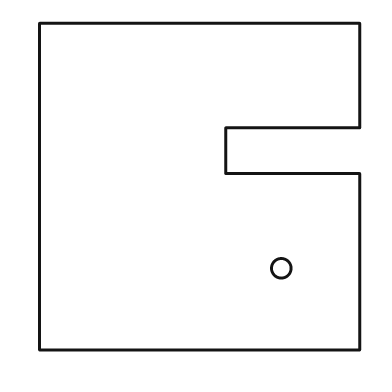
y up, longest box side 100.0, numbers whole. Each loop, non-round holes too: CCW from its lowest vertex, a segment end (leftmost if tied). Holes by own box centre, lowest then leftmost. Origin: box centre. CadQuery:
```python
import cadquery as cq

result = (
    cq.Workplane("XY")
    .moveTo(-49.0, -50.0)
    .lineTo(49.0, -50.0)
    .lineTo(49.0, 4.0)
    .lineTo(8.0, 4.0)
    .lineTo(8.0, 18.0)
    .lineTo(49.0, 18.0)
    .lineTo(49.0, 50.0)
    .lineTo(-49.0, 50.0)
    .close()
    .moveTo(25.0, -25.0)
    .circle(3.0)
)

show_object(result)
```